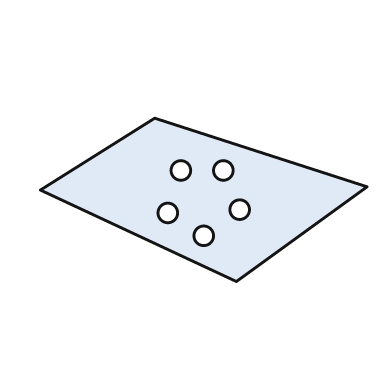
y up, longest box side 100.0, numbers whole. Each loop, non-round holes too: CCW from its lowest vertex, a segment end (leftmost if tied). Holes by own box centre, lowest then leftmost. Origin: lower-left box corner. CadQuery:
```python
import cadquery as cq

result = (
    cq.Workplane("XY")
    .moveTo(60.0, 0.0)
    .lineTo(100.0, 29.0)
    .lineTo(35.0, 50.0)
    .lineTo(0.0, 28.0)
    .close()
    .moveTo(50.0, 14.0)
    .circle(3.0)
    .moveTo(39.0, 21.0)
    .circle(3.0)
    .moveTo(61.0, 22.0)
    .circle(3.0)
    .moveTo(43.0, 34.0)
    .circle(3.0)
    .moveTo(56.0, 34.0)
    .circle(3.0)
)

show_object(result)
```